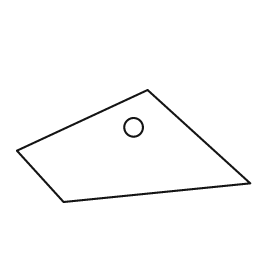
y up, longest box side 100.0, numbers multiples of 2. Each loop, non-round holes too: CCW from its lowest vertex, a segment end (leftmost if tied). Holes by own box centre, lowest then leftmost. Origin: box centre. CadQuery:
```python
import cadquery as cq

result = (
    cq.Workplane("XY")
    .moveTo(-30.0, -24.0)
    .lineTo(50.0, -16.0)
    .lineTo(6.0, 24.0)
    .lineTo(-50.0, -2.0)
    .close()
    .moveTo(0.0, 8.0)
    .circle(4.0)
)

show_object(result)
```